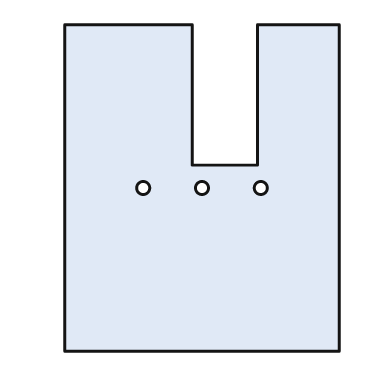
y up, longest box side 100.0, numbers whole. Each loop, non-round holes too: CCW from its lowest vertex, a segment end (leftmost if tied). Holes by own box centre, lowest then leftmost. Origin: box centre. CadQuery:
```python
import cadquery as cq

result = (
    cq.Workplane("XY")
    .moveTo(-42.0, -50.0)
    .lineTo(42.0, -50.0)
    .lineTo(42.0, 50.0)
    .lineTo(17.0, 50.0)
    .lineTo(17.0, 7.0)
    .lineTo(-3.0, 7.0)
    .lineTo(-3.0, 50.0)
    .lineTo(-42.0, 50.0)
    .close()
    .moveTo(-18.0, 0.0)
    .circle(2.0)
    .moveTo(0.0, 0.0)
    .circle(2.0)
    .moveTo(18.0, 0.0)
    .circle(2.0)
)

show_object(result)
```